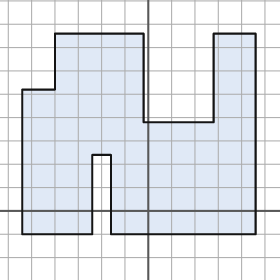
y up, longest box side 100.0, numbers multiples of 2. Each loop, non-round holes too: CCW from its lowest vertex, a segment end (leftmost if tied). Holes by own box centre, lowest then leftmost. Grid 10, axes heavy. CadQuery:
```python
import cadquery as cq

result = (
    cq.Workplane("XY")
    .moveTo(-54.0, -10.0)
    .lineTo(-24.0, -10.0)
    .lineTo(-24.0, 24.0)
    .lineTo(-16.0, 24.0)
    .lineTo(-16.0, -10.0)
    .lineTo(46.0, -10.0)
    .lineTo(46.0, 76.0)
    .lineTo(28.0, 76.0)
    .lineTo(28.0, 38.0)
    .lineTo(-2.0, 38.0)
    .lineTo(-2.0, 76.0)
    .lineTo(-40.0, 76.0)
    .lineTo(-40.0, 52.0)
    .lineTo(-54.0, 52.0)
    .close()
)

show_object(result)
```